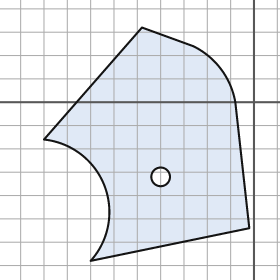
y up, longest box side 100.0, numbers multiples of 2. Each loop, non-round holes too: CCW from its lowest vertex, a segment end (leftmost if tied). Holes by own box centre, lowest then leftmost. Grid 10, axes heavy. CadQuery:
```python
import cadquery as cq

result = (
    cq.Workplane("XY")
    .moveTo(-70.0, -68.0)
    .lineTo(-2.0, -54.0)
    .lineTo(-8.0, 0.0)
    .threePointArc((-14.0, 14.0), (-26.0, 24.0))
    .lineTo(-48.0, 32.0)
    .lineTo(-90.0, -16.0)
    .threePointArc((-64.0, -36.0), (-70.0, -68.0))
    .close()
    .moveTo(-40.0, -32.0)
    .circle(4.0)
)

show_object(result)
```